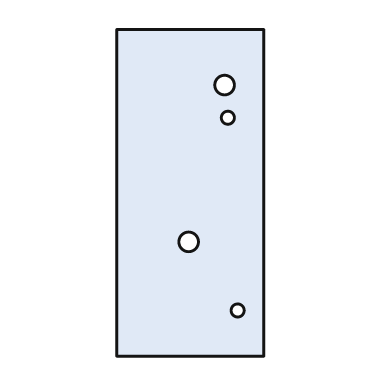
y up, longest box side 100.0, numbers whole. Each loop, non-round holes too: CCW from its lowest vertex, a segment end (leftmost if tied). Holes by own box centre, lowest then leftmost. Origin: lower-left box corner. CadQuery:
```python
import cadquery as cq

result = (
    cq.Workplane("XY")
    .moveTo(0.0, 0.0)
    .lineTo(45.0, 0.0)
    .lineTo(45.0, 100.0)
    .lineTo(0.0, 100.0)
    .close()
    .moveTo(37.0, 14.0)
    .circle(2.0)
    .moveTo(22.0, 35.0)
    .circle(3.0)
    .moveTo(34.0, 73.0)
    .circle(2.0)
    .moveTo(33.0, 83.0)
    .circle(3.0)
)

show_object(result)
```